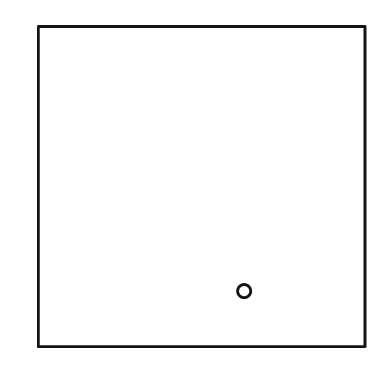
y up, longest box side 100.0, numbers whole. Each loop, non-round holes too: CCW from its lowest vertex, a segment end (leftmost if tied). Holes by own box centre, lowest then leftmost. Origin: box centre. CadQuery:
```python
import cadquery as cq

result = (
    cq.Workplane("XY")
    .moveTo(-50.0, -49.0)
    .lineTo(50.0, -49.0)
    .lineTo(50.0, 49.0)
    .lineTo(-50.0, 49.0)
    .close()
    .moveTo(13.0, -32.0)
    .circle(2.0)
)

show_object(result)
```